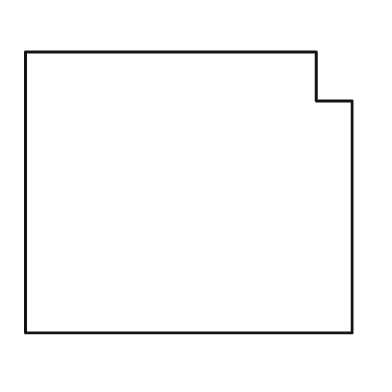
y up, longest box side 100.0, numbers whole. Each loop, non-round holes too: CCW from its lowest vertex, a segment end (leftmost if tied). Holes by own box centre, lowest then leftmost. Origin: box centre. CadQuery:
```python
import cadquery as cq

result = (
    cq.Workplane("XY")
    .moveTo(-50.0, -43.0)
    .lineTo(50.0, -43.0)
    .lineTo(50.0, 28.0)
    .lineTo(39.0, 28.0)
    .lineTo(39.0, 43.0)
    .lineTo(-50.0, 43.0)
    .close()
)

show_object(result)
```